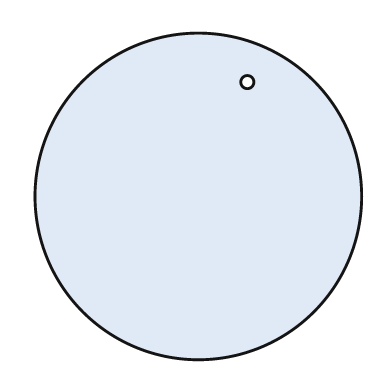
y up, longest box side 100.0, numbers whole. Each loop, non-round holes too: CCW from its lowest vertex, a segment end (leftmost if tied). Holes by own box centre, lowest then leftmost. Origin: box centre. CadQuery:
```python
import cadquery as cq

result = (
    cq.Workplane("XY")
    .moveTo(0.0, 0.0)
    .circle(50.0)
    .moveTo(15.0, 35.0)
    .circle(2.0)
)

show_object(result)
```